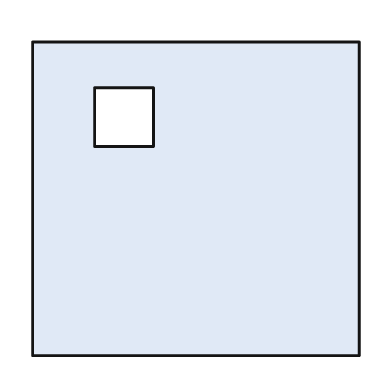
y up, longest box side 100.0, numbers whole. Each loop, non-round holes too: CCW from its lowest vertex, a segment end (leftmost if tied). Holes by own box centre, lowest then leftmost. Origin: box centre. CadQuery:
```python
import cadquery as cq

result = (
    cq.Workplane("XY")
    .moveTo(-50.0, -48.0)
    .lineTo(50.0, -48.0)
    .lineTo(50.0, 48.0)
    .lineTo(-50.0, 48.0)
    .close()
    .moveTo(-31.0, 16.0)
    .lineTo(-13.0, 16.0)
    .lineTo(-13.0, 34.0)
    .lineTo(-31.0, 34.0)
    .close()
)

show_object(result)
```